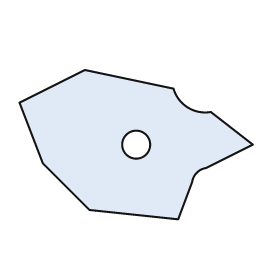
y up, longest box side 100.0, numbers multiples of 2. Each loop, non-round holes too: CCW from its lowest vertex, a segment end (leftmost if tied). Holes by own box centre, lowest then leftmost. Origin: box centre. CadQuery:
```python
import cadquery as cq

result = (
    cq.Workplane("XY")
    .moveTo(18.0, -32.0)
    .lineTo(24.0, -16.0)
    .threePointArc((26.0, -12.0), (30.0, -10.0))
    .lineTo(50.0, 0.0)
    .lineTo(32.0, 14.0)
    .threePointArc((22.0, 16.0), (16.0, 24.0))
    .lineTo(-22.0, 32.0)
    .lineTo(-50.0, 18.0)
    .lineTo(-40.0, -8.0)
    .lineTo(-20.0, -28.0)
    .close()
    .moveTo(0.0, 0.0)
    .circle(6.0)
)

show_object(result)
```